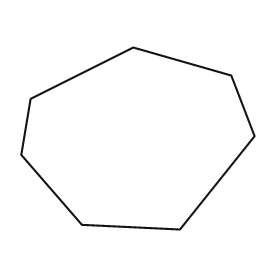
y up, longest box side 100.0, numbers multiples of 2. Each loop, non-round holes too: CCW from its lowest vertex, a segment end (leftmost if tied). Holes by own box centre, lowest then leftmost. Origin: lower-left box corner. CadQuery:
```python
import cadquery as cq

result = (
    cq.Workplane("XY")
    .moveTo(68.0, 0.0)
    .lineTo(100.0, 40.0)
    .lineTo(90.0, 66.0)
    .lineTo(48.0, 78.0)
    .lineTo(4.0, 56.0)
    .lineTo(0.0, 32.0)
    .lineTo(26.0, 2.0)
    .close()
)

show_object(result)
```